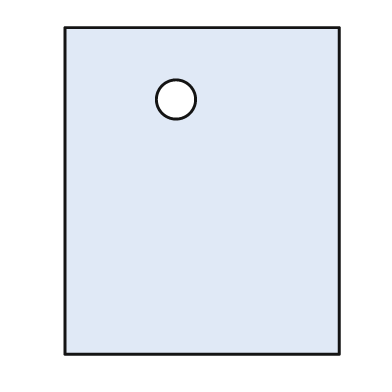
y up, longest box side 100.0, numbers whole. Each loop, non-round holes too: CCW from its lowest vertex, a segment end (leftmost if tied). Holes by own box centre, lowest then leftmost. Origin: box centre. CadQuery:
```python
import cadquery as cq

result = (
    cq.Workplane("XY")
    .moveTo(-42.0, -50.0)
    .lineTo(42.0, -50.0)
    .lineTo(42.0, 50.0)
    .lineTo(-42.0, 50.0)
    .close()
    .moveTo(-8.0, 28.0)
    .circle(6.0)
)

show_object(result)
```